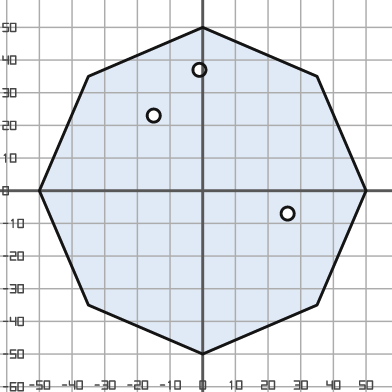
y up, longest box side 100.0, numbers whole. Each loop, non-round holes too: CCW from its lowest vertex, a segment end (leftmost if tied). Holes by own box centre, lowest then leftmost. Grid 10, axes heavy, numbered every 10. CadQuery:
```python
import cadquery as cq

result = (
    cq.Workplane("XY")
    .moveTo(0.0, -50.0)
    .lineTo(35.0, -35.0)
    .lineTo(50.0, 0.0)
    .lineTo(35.0, 35.0)
    .lineTo(0.0, 50.0)
    .lineTo(-35.0, 35.0)
    .lineTo(-50.0, 0.0)
    .lineTo(-35.0, -35.0)
    .close()
    .moveTo(26.0, -7.0)
    .circle(2.0)
    .moveTo(-15.0, 23.0)
    .circle(2.0)
    .moveTo(-1.0, 37.0)
    .circle(2.0)
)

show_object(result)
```